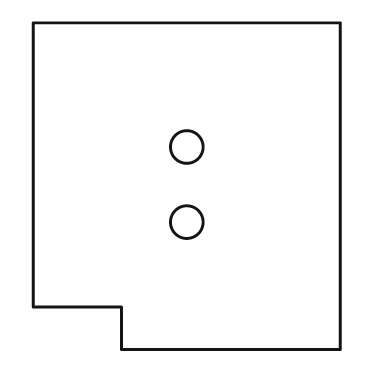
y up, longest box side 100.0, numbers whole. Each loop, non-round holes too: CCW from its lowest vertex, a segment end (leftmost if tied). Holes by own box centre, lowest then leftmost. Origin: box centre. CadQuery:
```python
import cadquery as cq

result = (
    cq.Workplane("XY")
    .moveTo(-20.0, -50.0)
    .lineTo(47.0, -50.0)
    .lineTo(47.0, 50.0)
    .lineTo(-47.0, 50.0)
    .lineTo(-47.0, -37.0)
    .lineTo(-20.0, -37.0)
    .close()
    .moveTo(0.0, -11.0)
    .circle(5.0)
    .moveTo(0.0, 12.0)
    .circle(5.0)
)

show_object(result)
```